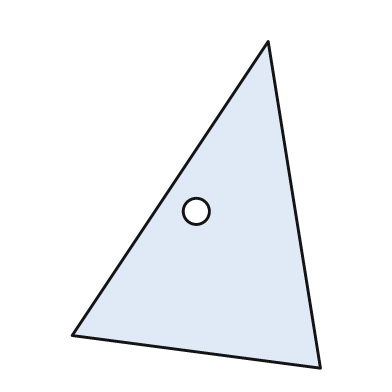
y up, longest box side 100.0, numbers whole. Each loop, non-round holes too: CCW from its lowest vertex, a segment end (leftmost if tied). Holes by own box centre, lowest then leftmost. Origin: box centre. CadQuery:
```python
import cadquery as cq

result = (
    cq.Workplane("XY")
    .moveTo(38.0, -50.0)
    .lineTo(22.0, 50.0)
    .lineTo(-38.0, -40.0)
    .close()
    .moveTo(0.0, -2.0)
    .circle(4.0)
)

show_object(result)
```